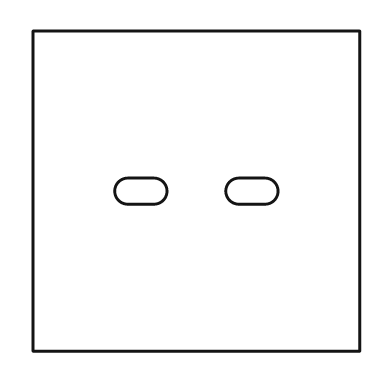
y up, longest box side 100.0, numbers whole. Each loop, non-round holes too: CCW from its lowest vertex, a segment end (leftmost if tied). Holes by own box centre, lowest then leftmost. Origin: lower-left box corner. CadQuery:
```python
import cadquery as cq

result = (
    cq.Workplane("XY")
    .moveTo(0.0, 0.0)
    .lineTo(100.0, 0.0)
    .lineTo(100.0, 98.0)
    .lineTo(0.0, 98.0)
    .close()
    .moveTo(29.0, 45.0)
    .lineTo(37.0, 45.0)
    .threePointArc((41.0, 49.0), (37.0, 53.0))
    .lineTo(29.0, 53.0)
    .threePointArc((25.0, 49.0), (29.0, 45.0))
    .close()
    .moveTo(63.0, 45.0)
    .lineTo(71.0, 45.0)
    .threePointArc((75.0, 49.0), (71.0, 53.0))
    .lineTo(63.0, 53.0)
    .threePointArc((59.0, 49.0), (63.0, 45.0))
    .close()
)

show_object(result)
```